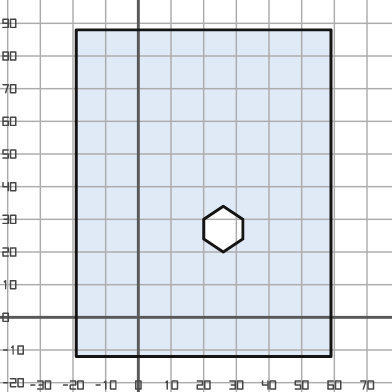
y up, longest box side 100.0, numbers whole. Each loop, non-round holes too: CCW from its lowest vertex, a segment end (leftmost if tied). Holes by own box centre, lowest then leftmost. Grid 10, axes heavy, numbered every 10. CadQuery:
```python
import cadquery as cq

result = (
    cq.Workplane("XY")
    .moveTo(-19.0, -12.0)
    .lineTo(59.0, -12.0)
    .lineTo(59.0, 88.0)
    .lineTo(-19.0, 88.0)
    .close()
    .moveTo(26.0, 20.0)
    .lineTo(32.0, 24.0)
    .lineTo(32.0, 30.0)
    .lineTo(26.0, 34.0)
    .lineTo(20.0, 30.0)
    .lineTo(20.0, 24.0)
    .close()
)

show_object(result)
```